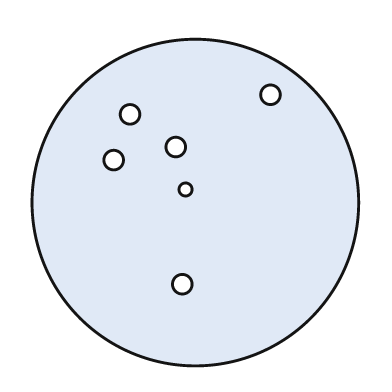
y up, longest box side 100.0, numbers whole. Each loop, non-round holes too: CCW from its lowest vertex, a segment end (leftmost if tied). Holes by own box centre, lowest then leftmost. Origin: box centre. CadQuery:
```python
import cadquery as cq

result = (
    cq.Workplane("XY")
    .moveTo(0.0, 0.0)
    .circle(50.0)
    .moveTo(-4.0, -25.0)
    .circle(3.0)
    .moveTo(-3.0, 4.0)
    .circle(2.0)
    .moveTo(-25.0, 13.0)
    .circle(3.0)
    .moveTo(-6.0, 17.0)
    .circle(3.0)
    .moveTo(-20.0, 27.0)
    .circle(3.0)
    .moveTo(23.0, 33.0)
    .circle(3.0)
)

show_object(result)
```